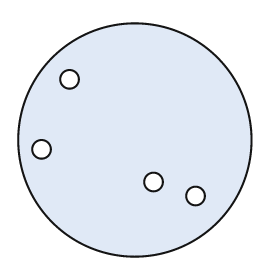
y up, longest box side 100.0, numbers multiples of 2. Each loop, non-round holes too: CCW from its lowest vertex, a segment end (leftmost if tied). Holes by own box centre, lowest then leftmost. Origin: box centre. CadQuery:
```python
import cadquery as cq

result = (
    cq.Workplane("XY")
    .moveTo(0.0, 0.0)
    .circle(50.0)
    .moveTo(26.0, -24.0)
    .circle(4.0)
    .moveTo(8.0, -18.0)
    .circle(4.0)
    .moveTo(-40.0, -4.0)
    .circle(4.0)
    .moveTo(-28.0, 26.0)
    .circle(4.0)
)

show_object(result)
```